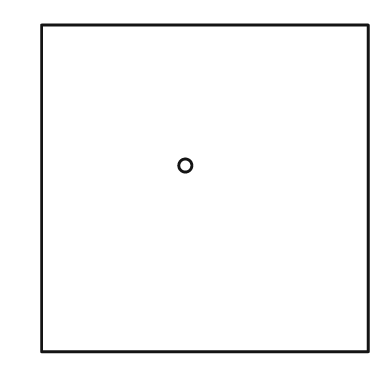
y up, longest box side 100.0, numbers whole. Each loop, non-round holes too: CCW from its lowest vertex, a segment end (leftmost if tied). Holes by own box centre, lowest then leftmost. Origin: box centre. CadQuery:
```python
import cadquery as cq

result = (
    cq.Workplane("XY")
    .moveTo(-50.0, -50.0)
    .lineTo(50.0, -50.0)
    .lineTo(50.0, 50.0)
    .lineTo(-50.0, 50.0)
    .close()
    .moveTo(-6.0, 7.0)
    .circle(2.0)
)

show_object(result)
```